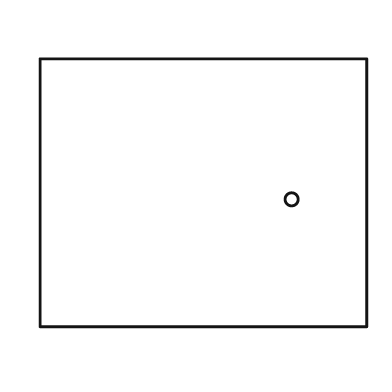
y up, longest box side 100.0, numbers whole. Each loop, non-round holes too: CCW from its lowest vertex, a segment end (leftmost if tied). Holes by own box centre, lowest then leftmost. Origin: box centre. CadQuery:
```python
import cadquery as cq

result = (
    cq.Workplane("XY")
    .moveTo(-50.0, -41.0)
    .lineTo(50.0, -41.0)
    .lineTo(50.0, 41.0)
    .lineTo(-50.0, 41.0)
    .close()
    .moveTo(27.0, -2.0)
    .circle(2.0)
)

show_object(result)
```